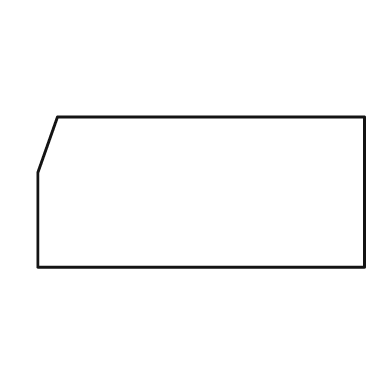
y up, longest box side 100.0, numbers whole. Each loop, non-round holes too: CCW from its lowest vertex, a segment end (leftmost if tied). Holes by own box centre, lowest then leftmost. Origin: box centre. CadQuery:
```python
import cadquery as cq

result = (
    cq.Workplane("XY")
    .moveTo(-50.0, -23.0)
    .lineTo(50.0, -23.0)
    .lineTo(50.0, 23.0)
    .lineTo(-44.0, 23.0)
    .lineTo(-50.0, 6.0)
    .close()
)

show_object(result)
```